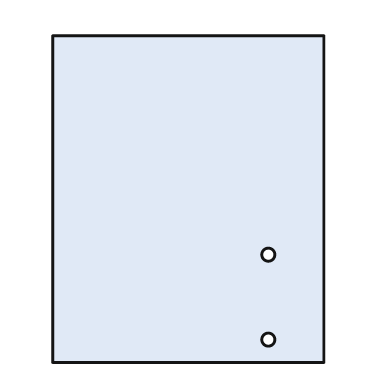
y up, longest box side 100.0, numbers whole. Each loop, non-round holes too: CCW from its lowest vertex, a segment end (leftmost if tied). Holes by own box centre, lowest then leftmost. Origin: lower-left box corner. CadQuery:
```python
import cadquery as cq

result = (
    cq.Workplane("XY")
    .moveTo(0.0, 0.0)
    .lineTo(83.0, 0.0)
    .lineTo(83.0, 100.0)
    .lineTo(0.0, 100.0)
    .close()
    .moveTo(66.0, 7.0)
    .circle(2.0)
    .moveTo(66.0, 33.0)
    .circle(2.0)
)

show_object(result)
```